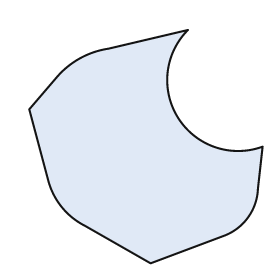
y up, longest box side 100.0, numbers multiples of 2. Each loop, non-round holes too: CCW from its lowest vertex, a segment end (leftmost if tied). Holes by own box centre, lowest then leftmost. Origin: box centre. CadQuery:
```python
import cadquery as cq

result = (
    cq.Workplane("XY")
    .moveTo(2.0, -50.0)
    .lineTo(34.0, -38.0)
    .threePointArc((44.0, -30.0), (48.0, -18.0))
    .lineTo(50.0, 0.0)
    .threePointArc((14.0, 12.0), (18.0, 50.0))
    .lineTo(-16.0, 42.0)
    .threePointArc((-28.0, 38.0), (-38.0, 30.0))
    .lineTo(-50.0, 16.0)
    .lineTo(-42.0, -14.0)
    .threePointArc((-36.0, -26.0), (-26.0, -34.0))
    .close()
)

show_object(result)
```